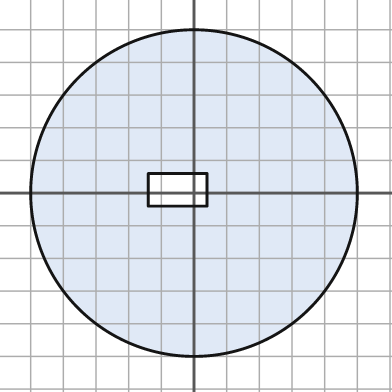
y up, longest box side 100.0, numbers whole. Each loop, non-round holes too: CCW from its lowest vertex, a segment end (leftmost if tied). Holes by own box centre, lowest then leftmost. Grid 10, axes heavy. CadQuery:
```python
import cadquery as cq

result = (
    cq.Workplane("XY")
    .moveTo(0.0, 0.0)
    .circle(50.0)
    .moveTo(-14.0, -4.0)
    .lineTo(4.0, -4.0)
    .lineTo(4.0, 6.0)
    .lineTo(-14.0, 6.0)
    .close()
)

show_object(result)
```